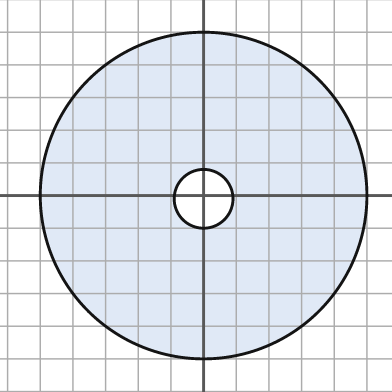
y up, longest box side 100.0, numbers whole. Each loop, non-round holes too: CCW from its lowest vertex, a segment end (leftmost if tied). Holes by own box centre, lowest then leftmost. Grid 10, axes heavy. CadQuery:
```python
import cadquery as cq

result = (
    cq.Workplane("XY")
    .moveTo(0.0, 0.0)
    .circle(50.0)
    .moveTo(0.0, -1.0)
    .circle(9.0)
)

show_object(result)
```